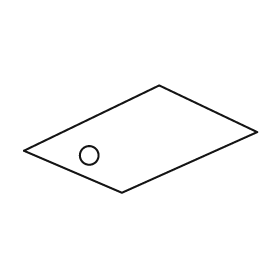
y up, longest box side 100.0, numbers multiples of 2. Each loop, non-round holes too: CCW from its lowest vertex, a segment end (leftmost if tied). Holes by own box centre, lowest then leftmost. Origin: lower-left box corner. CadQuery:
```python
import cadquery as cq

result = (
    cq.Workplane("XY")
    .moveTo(42.0, 0.0)
    .lineTo(100.0, 26.0)
    .lineTo(58.0, 46.0)
    .lineTo(0.0, 18.0)
    .close()
    .moveTo(28.0, 16.0)
    .circle(4.0)
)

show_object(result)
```